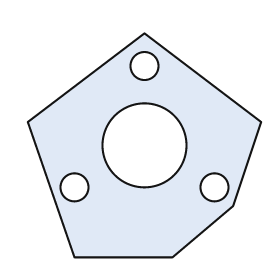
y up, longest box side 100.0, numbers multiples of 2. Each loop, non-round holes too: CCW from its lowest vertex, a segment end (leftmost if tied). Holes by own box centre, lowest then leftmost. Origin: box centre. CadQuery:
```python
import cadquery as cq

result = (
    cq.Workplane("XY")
    .moveTo(-30.0, -48.0)
    .lineTo(12.0, -48.0)
    .lineTo(38.0, -26.0)
    .lineTo(50.0, 10.0)
    .lineTo(0.0, 48.0)
    .lineTo(-50.0, 10.0)
    .close()
    .moveTo(-30.0, -18.0)
    .circle(6.0)
    .moveTo(30.0, -18.0)
    .circle(6.0)
    .moveTo(0.0, 0.0)
    .circle(18.0)
    .moveTo(0.0, 34.0)
    .circle(6.0)
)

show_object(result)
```